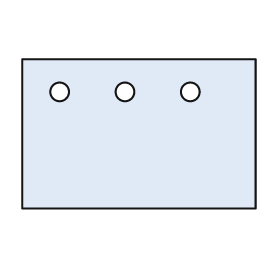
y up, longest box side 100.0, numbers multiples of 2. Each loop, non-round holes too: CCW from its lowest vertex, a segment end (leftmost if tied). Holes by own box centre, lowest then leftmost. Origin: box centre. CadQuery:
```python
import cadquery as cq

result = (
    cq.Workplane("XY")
    .moveTo(-50.0, -32.0)
    .lineTo(50.0, -32.0)
    .lineTo(50.0, 32.0)
    .lineTo(-50.0, 32.0)
    .close()
    .moveTo(-34.0, 18.0)
    .circle(4.0)
    .moveTo(-6.0, 18.0)
    .circle(4.0)
    .moveTo(22.0, 18.0)
    .circle(4.0)
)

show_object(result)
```